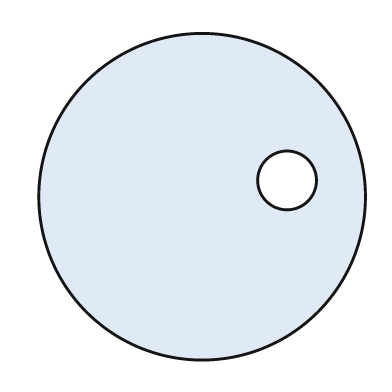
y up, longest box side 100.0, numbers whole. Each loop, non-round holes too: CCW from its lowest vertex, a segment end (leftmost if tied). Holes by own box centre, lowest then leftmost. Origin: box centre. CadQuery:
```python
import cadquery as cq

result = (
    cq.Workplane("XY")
    .moveTo(0.0, 0.0)
    .circle(50.0)
    .moveTo(26.0, 5.0)
    .circle(9.0)
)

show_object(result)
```